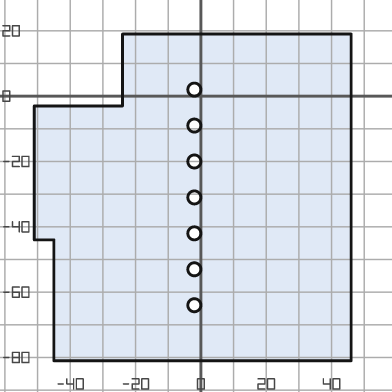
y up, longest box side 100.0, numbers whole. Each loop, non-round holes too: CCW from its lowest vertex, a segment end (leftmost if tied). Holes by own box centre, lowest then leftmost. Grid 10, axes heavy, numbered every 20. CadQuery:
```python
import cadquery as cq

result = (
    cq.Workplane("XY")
    .moveTo(-45.0, -81.0)
    .lineTo(46.0, -81.0)
    .lineTo(46.0, 19.0)
    .lineTo(-24.0, 19.0)
    .lineTo(-24.0, -3.0)
    .lineTo(-51.0, -3.0)
    .lineTo(-51.0, -44.0)
    .lineTo(-45.0, -44.0)
    .close()
    .moveTo(-2.0, -64.0)
    .circle(2.0)
    .moveTo(-2.0, -53.0)
    .circle(2.0)
    .moveTo(-2.0, -42.0)
    .circle(2.0)
    .moveTo(-2.0, -31.0)
    .circle(2.0)
    .moveTo(-2.0, -20.0)
    .circle(2.0)
    .moveTo(-2.0, -9.0)
    .circle(2.0)
    .moveTo(-2.0, 2.0)
    .circle(2.0)
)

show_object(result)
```